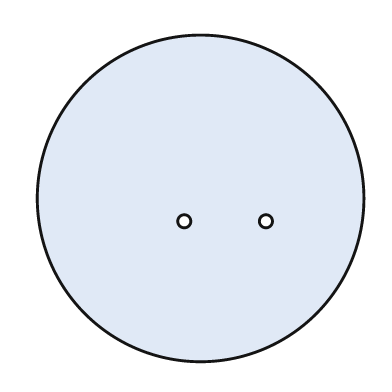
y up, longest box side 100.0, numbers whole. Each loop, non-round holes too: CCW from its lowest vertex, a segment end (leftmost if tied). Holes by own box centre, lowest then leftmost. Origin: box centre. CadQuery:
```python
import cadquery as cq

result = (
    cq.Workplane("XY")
    .moveTo(0.0, 0.0)
    .circle(50.0)
    .moveTo(-5.0, -7.0)
    .circle(2.0)
    .moveTo(20.0, -7.0)
    .circle(2.0)
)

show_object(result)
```